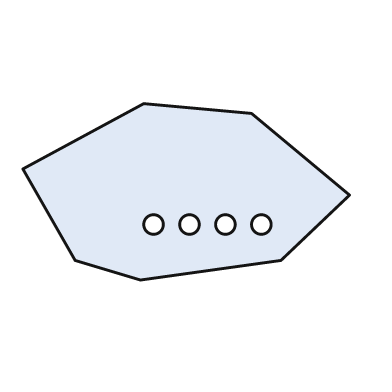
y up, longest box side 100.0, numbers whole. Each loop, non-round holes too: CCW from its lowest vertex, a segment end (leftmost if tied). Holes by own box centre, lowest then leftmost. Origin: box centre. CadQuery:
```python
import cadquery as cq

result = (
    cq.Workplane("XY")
    .moveTo(-14.0, -27.0)
    .lineTo(29.0, -21.0)
    .lineTo(50.0, -1.0)
    .lineTo(20.0, 24.0)
    .lineTo(-13.0, 27.0)
    .lineTo(-50.0, 7.0)
    .lineTo(-34.0, -21.0)
    .close()
    .moveTo(-10.0, -10.0)
    .circle(3.0)
    .moveTo(1.0, -10.0)
    .circle(3.0)
    .moveTo(12.0, -10.0)
    .circle(3.0)
    .moveTo(23.0, -10.0)
    .circle(3.0)
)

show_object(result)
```